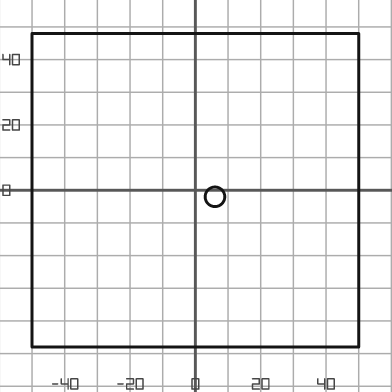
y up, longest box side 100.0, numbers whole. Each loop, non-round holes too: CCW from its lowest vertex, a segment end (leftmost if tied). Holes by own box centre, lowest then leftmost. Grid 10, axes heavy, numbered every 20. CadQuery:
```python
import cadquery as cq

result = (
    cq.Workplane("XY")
    .moveTo(-50.0, -48.0)
    .lineTo(50.0, -48.0)
    .lineTo(50.0, 48.0)
    .lineTo(-50.0, 48.0)
    .close()
    .moveTo(6.0, -2.0)
    .circle(3.0)
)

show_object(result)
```